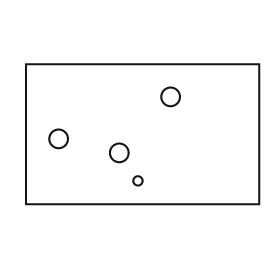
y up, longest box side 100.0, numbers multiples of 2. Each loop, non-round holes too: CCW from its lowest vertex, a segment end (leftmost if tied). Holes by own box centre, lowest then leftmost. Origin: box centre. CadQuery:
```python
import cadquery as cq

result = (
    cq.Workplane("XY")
    .moveTo(-50.0, -30.0)
    .lineTo(50.0, -30.0)
    .lineTo(50.0, 30.0)
    .lineTo(-50.0, 30.0)
    .close()
    .moveTo(-2.0, -20.0)
    .circle(2.0)
    .moveTo(-10.0, -8.0)
    .circle(4.0)
    .moveTo(-36.0, -2.0)
    .circle(4.0)
    .moveTo(12.0, 16.0)
    .circle(4.0)
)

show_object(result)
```